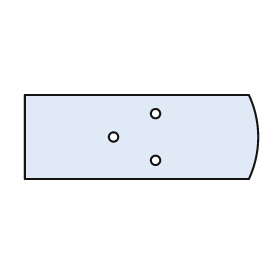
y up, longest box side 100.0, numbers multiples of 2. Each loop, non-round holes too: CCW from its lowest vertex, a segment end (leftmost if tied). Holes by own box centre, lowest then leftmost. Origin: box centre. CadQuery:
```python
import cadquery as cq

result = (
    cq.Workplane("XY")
    .moveTo(-50.0, -18.0)
    .lineTo(46.0, -18.0)
    .threePointArc((50.0, 0.0), (46.0, 18.0))
    .lineTo(-50.0, 18.0)
    .close()
    .moveTo(6.0, -10.0)
    .circle(2.0)
    .moveTo(-12.0, 0.0)
    .circle(2.0)
    .moveTo(6.0, 10.0)
    .circle(2.0)
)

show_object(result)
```